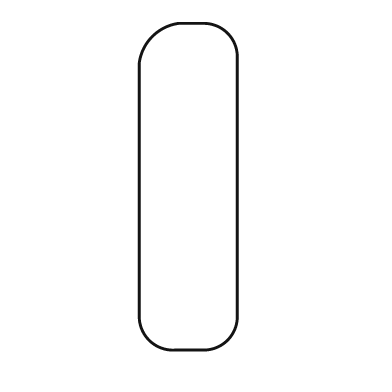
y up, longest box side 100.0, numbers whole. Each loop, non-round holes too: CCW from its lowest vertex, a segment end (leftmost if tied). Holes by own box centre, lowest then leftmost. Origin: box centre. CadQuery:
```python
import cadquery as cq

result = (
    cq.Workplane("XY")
    .moveTo(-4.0, -50.0)
    .lineTo(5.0, -50.0)
    .threePointArc((12.0, -47.0), (15.0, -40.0))
    .lineTo(15.0, 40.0)
    .threePointArc((12.0, 47.0), (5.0, 50.0))
    .lineTo(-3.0, 50.0)
    .threePointArc((-11.0, 46.0), (-15.0, 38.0))
    .lineTo(-15.0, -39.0)
    .threePointArc((-12.0, -47.0), (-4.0, -50.0))
    .close()
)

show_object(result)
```